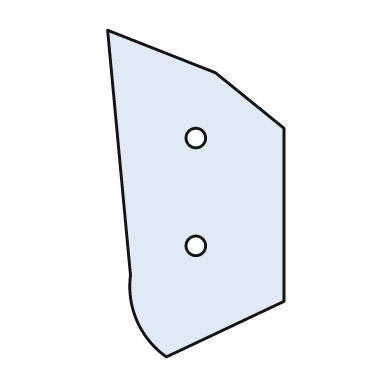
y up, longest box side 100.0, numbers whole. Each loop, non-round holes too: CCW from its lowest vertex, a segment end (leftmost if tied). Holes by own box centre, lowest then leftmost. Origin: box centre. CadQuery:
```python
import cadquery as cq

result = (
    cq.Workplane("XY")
    .moveTo(-9.0, -50.0)
    .lineTo(27.0, -33.0)
    .lineTo(27.0, 20.0)
    .lineTo(6.0, 37.0)
    .lineTo(-27.0, 50.0)
    .lineTo(-20.0, -25.0)
    .threePointArc((-18.0, -39.0), (-9.0, -50.0))
    .close()
    .moveTo(0.0, -16.0)
    .circle(3.0)
    .moveTo(0.0, 17.0)
    .circle(3.0)
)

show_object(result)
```